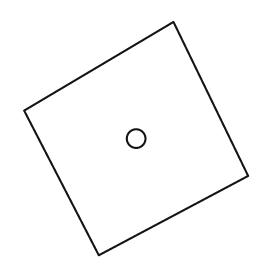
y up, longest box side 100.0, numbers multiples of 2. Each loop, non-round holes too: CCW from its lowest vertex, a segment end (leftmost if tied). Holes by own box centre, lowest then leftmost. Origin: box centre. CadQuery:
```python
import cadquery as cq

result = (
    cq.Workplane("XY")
    .moveTo(-16.0, -50.0)
    .lineTo(48.0, -16.0)
    .lineTo(16.0, 50.0)
    .lineTo(-48.0, 12.0)
    .close()
    .moveTo(0.0, 0.0)
    .circle(4.0)
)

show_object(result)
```